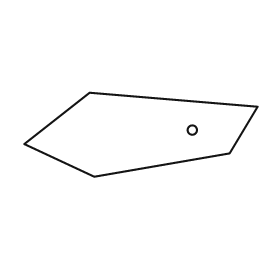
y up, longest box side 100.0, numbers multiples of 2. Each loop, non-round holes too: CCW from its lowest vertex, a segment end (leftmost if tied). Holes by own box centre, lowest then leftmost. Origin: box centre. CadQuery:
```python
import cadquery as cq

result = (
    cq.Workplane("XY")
    .moveTo(-20.0, -18.0)
    .lineTo(38.0, -8.0)
    .lineTo(50.0, 12.0)
    .lineTo(-22.0, 18.0)
    .lineTo(-50.0, -4.0)
    .close()
    .moveTo(22.0, 2.0)
    .circle(2.0)
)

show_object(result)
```